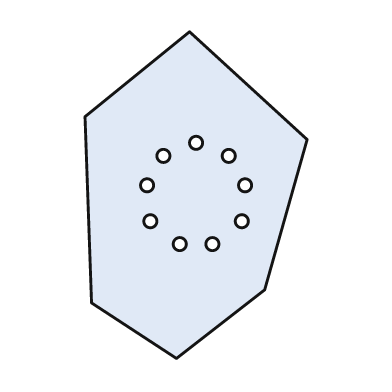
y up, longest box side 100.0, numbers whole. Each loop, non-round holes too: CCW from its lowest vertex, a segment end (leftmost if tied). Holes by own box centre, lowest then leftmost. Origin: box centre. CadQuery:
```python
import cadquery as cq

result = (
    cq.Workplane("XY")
    .moveTo(-6.0, -50.0)
    .lineTo(21.0, -29.0)
    .lineTo(34.0, 17.0)
    .lineTo(-2.0, 50.0)
    .lineTo(-34.0, 24.0)
    .lineTo(-32.0, -33.0)
    .close()
    .moveTo(-5.0, -15.0)
    .circle(2.0)
    .moveTo(5.0, -15.0)
    .circle(2.0)
    .moveTo(-14.0, -8.0)
    .circle(2.0)
    .moveTo(14.0, -8.0)
    .circle(2.0)
    .moveTo(-15.0, 3.0)
    .circle(2.0)
    .moveTo(15.0, 3.0)
    .circle(2.0)
    .moveTo(-10.0, 12.0)
    .circle(2.0)
    .moveTo(10.0, 12.0)
    .circle(2.0)
    .moveTo(0.0, 16.0)
    .circle(2.0)
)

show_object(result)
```